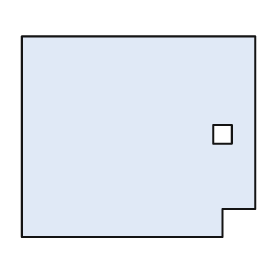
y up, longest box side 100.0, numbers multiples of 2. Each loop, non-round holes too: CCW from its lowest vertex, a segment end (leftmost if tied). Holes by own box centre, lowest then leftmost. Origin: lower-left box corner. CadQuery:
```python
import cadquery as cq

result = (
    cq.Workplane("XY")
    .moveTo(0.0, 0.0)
    .lineTo(86.0, 0.0)
    .lineTo(86.0, 12.0)
    .lineTo(100.0, 12.0)
    .lineTo(100.0, 86.0)
    .lineTo(0.0, 86.0)
    .close()
    .moveTo(82.0, 40.0)
    .lineTo(90.0, 40.0)
    .lineTo(90.0, 48.0)
    .lineTo(82.0, 48.0)
    .close()
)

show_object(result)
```